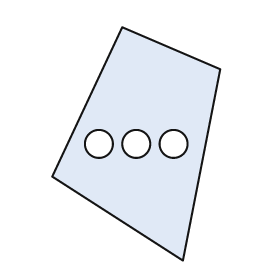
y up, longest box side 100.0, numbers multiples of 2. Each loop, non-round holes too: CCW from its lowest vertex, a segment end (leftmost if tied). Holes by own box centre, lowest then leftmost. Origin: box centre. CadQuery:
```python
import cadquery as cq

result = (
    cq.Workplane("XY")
    .moveTo(20.0, -50.0)
    .lineTo(36.0, 32.0)
    .lineTo(-6.0, 50.0)
    .lineTo(-36.0, -14.0)
    .close()
    .moveTo(-16.0, 0.0)
    .circle(6.0)
    .moveTo(0.0, 0.0)
    .circle(6.0)
    .moveTo(16.0, 0.0)
    .circle(6.0)
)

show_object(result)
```